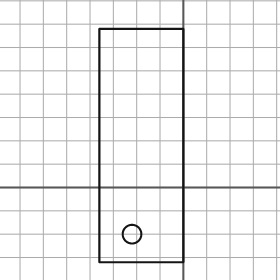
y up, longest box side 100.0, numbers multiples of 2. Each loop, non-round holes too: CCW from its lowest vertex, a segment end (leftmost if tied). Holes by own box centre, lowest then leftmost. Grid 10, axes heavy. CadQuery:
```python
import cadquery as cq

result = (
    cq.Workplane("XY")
    .moveTo(-36.0, -32.0)
    .lineTo(0.0, -32.0)
    .lineTo(0.0, 68.0)
    .lineTo(-36.0, 68.0)
    .close()
    .moveTo(-22.0, -20.0)
    .circle(4.0)
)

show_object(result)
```